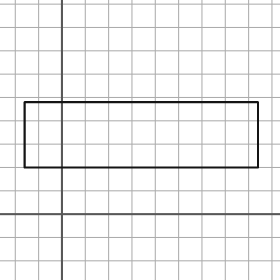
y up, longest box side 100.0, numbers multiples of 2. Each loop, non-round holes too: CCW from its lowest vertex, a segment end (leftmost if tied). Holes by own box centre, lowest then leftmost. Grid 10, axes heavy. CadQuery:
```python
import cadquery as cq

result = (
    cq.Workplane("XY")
    .moveTo(-16.0, 20.0)
    .lineTo(84.0, 20.0)
    .lineTo(84.0, 48.0)
    .lineTo(-16.0, 48.0)
    .close()
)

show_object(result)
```